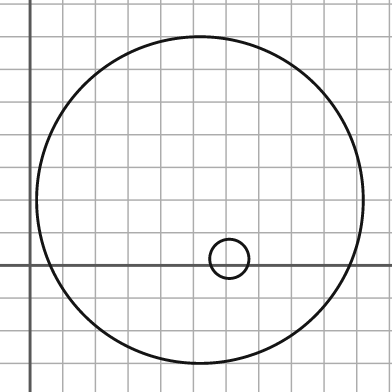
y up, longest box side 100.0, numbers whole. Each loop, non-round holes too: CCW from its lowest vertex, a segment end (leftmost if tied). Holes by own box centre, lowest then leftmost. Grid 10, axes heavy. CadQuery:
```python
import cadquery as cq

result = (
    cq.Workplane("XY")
    .moveTo(52.0, 20.0)
    .circle(50.0)
    .moveTo(61.0, 2.0)
    .circle(6.0)
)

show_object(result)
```